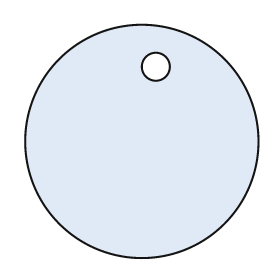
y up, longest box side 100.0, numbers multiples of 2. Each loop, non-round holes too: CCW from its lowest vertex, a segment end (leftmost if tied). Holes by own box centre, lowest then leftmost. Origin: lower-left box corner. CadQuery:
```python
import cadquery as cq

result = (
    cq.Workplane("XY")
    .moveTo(50.0, 50.0)
    .circle(50.0)
    .moveTo(56.0, 82.0)
    .circle(6.0)
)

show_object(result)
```